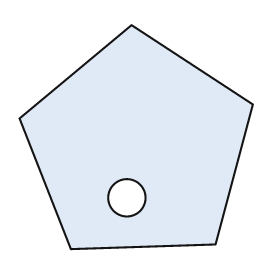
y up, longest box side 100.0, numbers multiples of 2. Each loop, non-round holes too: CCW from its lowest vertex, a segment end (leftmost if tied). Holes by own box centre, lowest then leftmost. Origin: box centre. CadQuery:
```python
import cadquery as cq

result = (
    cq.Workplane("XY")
    .moveTo(-28.0, -48.0)
    .lineTo(34.0, -46.0)
    .lineTo(50.0, 14.0)
    .lineTo(-2.0, 48.0)
    .lineTo(-50.0, 8.0)
    .close()
    .moveTo(-4.0, -26.0)
    .circle(8.0)
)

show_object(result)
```